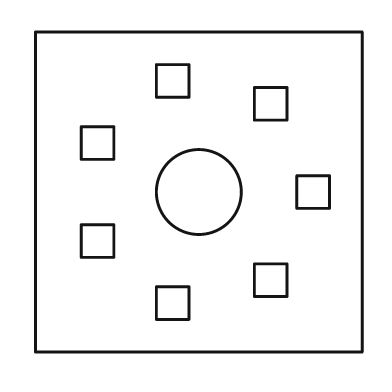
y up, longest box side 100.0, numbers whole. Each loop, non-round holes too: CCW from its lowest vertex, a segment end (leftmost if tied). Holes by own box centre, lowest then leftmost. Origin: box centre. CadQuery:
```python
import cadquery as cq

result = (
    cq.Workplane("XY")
    .moveTo(-50.0, -49.0)
    .lineTo(50.0, -49.0)
    .lineTo(50.0, 49.0)
    .lineTo(-50.0, 49.0)
    .close()
    .moveTo(-13.0, -39.0)
    .lineTo(-3.0, -39.0)
    .lineTo(-3.0, -29.0)
    .lineTo(-13.0, -29.0)
    .close()
    .moveTo(17.0, -32.0)
    .lineTo(27.0, -32.0)
    .lineTo(27.0, -22.0)
    .lineTo(17.0, -22.0)
    .close()
    .moveTo(-36.0, -20.0)
    .lineTo(-26.0, -20.0)
    .lineTo(-26.0, -10.0)
    .lineTo(-36.0, -10.0)
    .close()
    .moveTo(0.0, 0.0)
    .circle(13.0)
    .moveTo(30.0, -5.0)
    .lineTo(40.0, -5.0)
    .lineTo(40.0, 5.0)
    .lineTo(30.0, 5.0)
    .close()
    .moveTo(-36.0, 10.0)
    .lineTo(-26.0, 10.0)
    .lineTo(-26.0, 20.0)
    .lineTo(-36.0, 20.0)
    .close()
    .moveTo(17.0, 22.0)
    .lineTo(27.0, 22.0)
    .lineTo(27.0, 32.0)
    .lineTo(17.0, 32.0)
    .close()
    .moveTo(-13.0, 29.0)
    .lineTo(-3.0, 29.0)
    .lineTo(-3.0, 39.0)
    .lineTo(-13.0, 39.0)
    .close()
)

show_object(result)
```